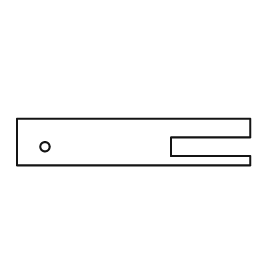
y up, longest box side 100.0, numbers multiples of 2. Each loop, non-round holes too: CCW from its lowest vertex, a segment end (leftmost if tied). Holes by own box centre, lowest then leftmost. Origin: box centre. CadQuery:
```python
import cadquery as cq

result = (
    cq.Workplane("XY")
    .moveTo(-50.0, -10.0)
    .lineTo(50.0, -10.0)
    .lineTo(50.0, -6.0)
    .lineTo(16.0, -6.0)
    .lineTo(16.0, 2.0)
    .lineTo(50.0, 2.0)
    .lineTo(50.0, 10.0)
    .lineTo(-50.0, 10.0)
    .close()
    .moveTo(-38.0, -2.0)
    .circle(2.0)
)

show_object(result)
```